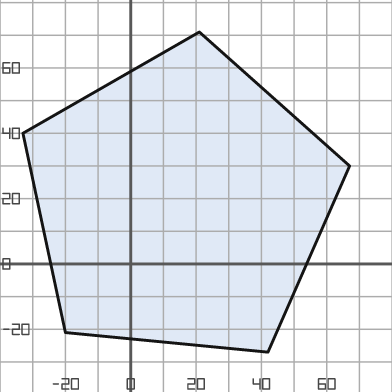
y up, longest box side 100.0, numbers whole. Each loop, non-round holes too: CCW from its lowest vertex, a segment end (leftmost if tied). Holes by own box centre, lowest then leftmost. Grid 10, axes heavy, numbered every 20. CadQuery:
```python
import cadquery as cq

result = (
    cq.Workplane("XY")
    .moveTo(42.0, -27.0)
    .lineTo(67.0, 30.0)
    .lineTo(21.0, 71.0)
    .lineTo(-33.0, 40.0)
    .lineTo(-20.0, -21.0)
    .close()
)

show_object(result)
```